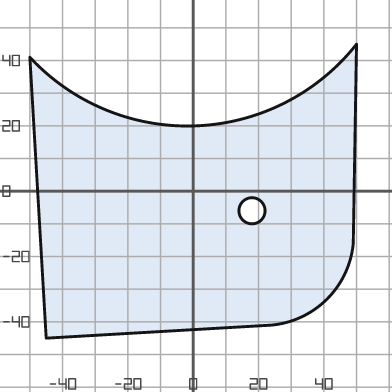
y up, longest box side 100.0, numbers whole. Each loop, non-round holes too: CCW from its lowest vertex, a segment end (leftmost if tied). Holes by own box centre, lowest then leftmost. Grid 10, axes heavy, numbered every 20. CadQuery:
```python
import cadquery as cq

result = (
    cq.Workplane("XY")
    .moveTo(-45.0, -45.0)
    .lineTo(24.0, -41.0)
    .threePointArc((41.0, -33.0), (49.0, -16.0))
    .lineTo(50.0, 45.0)
    .threePointArc((1.0, 20.0), (-50.0, 41.0))
    .close()
    .moveTo(18.0, -6.0)
    .circle(4.0)
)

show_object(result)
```